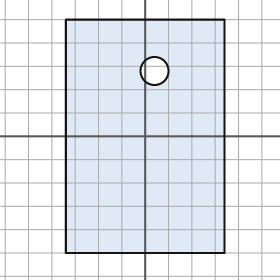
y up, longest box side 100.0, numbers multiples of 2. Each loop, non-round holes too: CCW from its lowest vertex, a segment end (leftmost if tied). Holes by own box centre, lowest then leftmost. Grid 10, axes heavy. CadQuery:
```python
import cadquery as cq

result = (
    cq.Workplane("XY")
    .moveTo(-34.0, -50.0)
    .lineTo(34.0, -50.0)
    .lineTo(34.0, 50.0)
    .lineTo(-34.0, 50.0)
    .close()
    .moveTo(4.0, 28.0)
    .circle(6.0)
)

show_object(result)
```